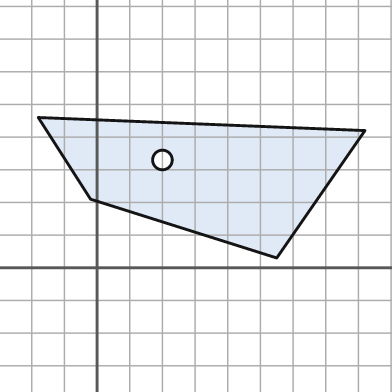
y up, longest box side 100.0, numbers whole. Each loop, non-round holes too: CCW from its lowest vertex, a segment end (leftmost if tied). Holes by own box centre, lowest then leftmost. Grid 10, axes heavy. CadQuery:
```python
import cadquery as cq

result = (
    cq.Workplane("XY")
    .moveTo(55.0, 3.0)
    .lineTo(82.0, 42.0)
    .lineTo(-18.0, 46.0)
    .lineTo(-2.0, 21.0)
    .close()
    .moveTo(20.0, 33.0)
    .circle(3.0)
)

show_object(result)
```